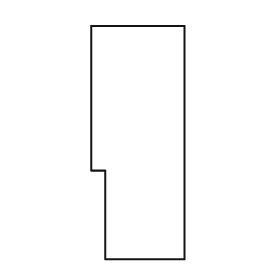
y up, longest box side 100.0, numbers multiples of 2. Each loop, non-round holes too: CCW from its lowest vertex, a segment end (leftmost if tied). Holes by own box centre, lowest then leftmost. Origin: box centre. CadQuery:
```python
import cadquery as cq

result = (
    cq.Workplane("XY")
    .moveTo(-14.0, -50.0)
    .lineTo(20.0, -50.0)
    .lineTo(20.0, 50.0)
    .lineTo(-20.0, 50.0)
    .lineTo(-20.0, -12.0)
    .lineTo(-14.0, -12.0)
    .close()
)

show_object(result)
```